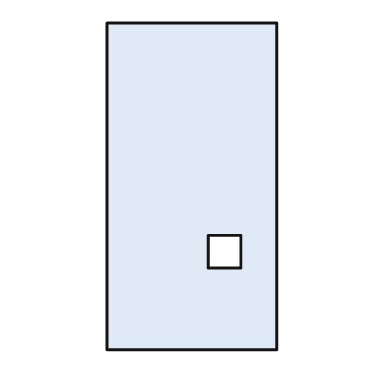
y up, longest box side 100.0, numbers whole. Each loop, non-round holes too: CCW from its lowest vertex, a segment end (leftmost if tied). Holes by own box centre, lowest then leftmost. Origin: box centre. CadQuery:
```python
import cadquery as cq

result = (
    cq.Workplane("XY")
    .moveTo(-26.0, -50.0)
    .lineTo(26.0, -50.0)
    .lineTo(26.0, 50.0)
    .lineTo(-26.0, 50.0)
    .close()
    .moveTo(5.0, -25.0)
    .lineTo(15.0, -25.0)
    .lineTo(15.0, -15.0)
    .lineTo(5.0, -15.0)
    .close()
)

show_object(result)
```